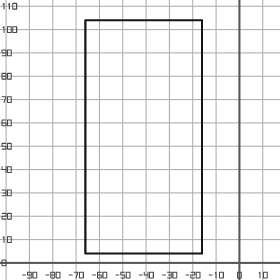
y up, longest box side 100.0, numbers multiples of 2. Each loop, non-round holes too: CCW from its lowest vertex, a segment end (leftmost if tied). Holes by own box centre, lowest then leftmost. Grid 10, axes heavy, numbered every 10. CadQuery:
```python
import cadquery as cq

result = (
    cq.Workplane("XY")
    .moveTo(-66.0, 4.0)
    .lineTo(-16.0, 4.0)
    .lineTo(-16.0, 104.0)
    .lineTo(-66.0, 104.0)
    .close()
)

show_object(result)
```